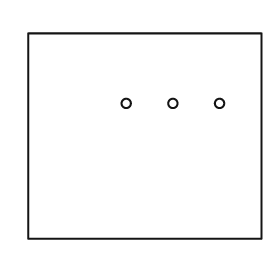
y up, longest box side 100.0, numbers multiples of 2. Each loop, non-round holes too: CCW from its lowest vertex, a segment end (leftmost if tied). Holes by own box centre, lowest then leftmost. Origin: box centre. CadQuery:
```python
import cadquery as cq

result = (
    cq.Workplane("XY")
    .moveTo(-50.0, -44.0)
    .lineTo(50.0, -44.0)
    .lineTo(50.0, 44.0)
    .lineTo(-50.0, 44.0)
    .close()
    .moveTo(-8.0, 14.0)
    .circle(2.0)
    .moveTo(12.0, 14.0)
    .circle(2.0)
    .moveTo(32.0, 14.0)
    .circle(2.0)
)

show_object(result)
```